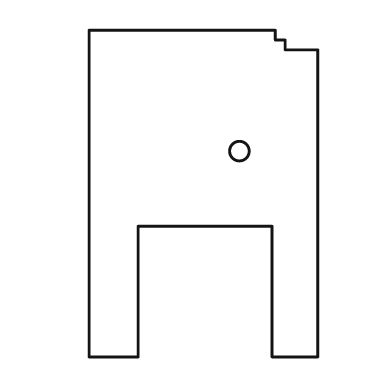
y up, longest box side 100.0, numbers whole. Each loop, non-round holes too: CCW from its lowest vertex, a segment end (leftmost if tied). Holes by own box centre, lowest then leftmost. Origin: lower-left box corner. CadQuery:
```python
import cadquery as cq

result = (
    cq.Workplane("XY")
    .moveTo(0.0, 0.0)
    .lineTo(15.0, 0.0)
    .lineTo(15.0, 40.0)
    .lineTo(56.0, 40.0)
    .lineTo(56.0, 0.0)
    .lineTo(70.0, 0.0)
    .lineTo(70.0, 94.0)
    .lineTo(60.0, 94.0)
    .lineTo(60.0, 97.0)
    .lineTo(57.0, 97.0)
    .lineTo(57.0, 100.0)
    .lineTo(0.0, 100.0)
    .close()
    .moveTo(46.0, 63.0)
    .circle(3.0)
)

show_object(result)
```